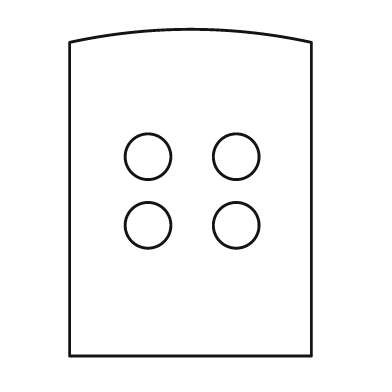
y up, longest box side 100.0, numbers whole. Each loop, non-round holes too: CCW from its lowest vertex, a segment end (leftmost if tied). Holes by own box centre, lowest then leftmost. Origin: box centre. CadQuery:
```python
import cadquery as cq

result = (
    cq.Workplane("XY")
    .moveTo(-37.0, -50.0)
    .lineTo(37.0, -50.0)
    .lineTo(37.0, 46.0)
    .threePointArc((0.0, 50.0), (-37.0, 46.0))
    .close()
    .moveTo(-13.0, -10.0)
    .circle(7.0)
    .moveTo(14.0, -10.0)
    .circle(7.0)
    .moveTo(-13.0, 11.0)
    .circle(7.0)
    .moveTo(14.0, 11.0)
    .circle(7.0)
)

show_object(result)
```